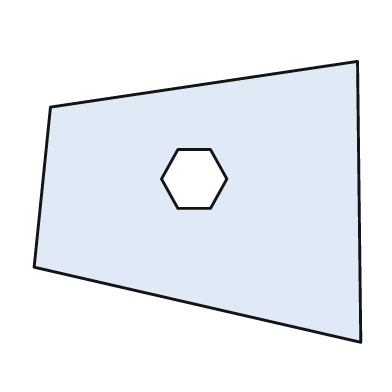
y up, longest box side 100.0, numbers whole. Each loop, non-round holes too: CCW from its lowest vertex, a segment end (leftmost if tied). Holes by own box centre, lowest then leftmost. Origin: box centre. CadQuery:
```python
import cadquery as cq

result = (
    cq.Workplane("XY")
    .moveTo(50.0, -43.0)
    .lineTo(49.0, 43.0)
    .lineTo(-45.0, 29.0)
    .lineTo(-50.0, -20.0)
    .close()
    .moveTo(-6.0, -2.0)
    .lineTo(4.0, -2.0)
    .lineTo(9.0, 7.0)
    .lineTo(4.0, 16.0)
    .lineTo(-6.0, 16.0)
    .lineTo(-11.0, 7.0)
    .close()
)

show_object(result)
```